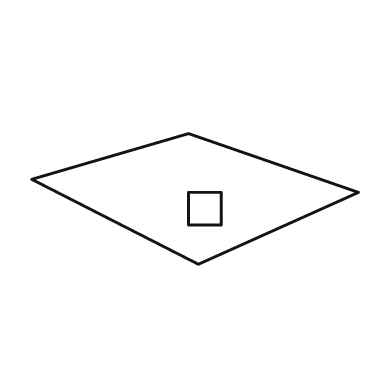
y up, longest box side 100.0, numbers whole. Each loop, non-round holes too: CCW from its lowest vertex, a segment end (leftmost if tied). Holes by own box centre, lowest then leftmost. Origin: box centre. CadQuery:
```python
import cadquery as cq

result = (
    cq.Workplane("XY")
    .moveTo(1.0, -20.0)
    .lineTo(50.0, 2.0)
    .lineTo(-2.0, 20.0)
    .lineTo(-50.0, 6.0)
    .close()
    .moveTo(-2.0, -8.0)
    .lineTo(8.0, -8.0)
    .lineTo(8.0, 2.0)
    .lineTo(-2.0, 2.0)
    .close()
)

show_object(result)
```